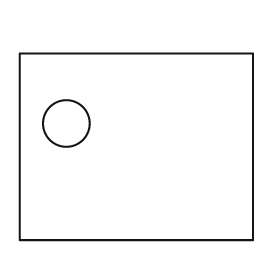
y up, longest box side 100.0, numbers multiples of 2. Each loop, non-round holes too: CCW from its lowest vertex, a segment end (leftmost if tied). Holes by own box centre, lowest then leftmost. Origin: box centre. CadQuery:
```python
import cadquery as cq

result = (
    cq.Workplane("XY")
    .moveTo(-50.0, -40.0)
    .lineTo(50.0, -40.0)
    .lineTo(50.0, 40.0)
    .lineTo(-50.0, 40.0)
    .close()
    .moveTo(-30.0, 10.0)
    .circle(10.0)
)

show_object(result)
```